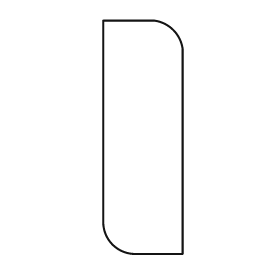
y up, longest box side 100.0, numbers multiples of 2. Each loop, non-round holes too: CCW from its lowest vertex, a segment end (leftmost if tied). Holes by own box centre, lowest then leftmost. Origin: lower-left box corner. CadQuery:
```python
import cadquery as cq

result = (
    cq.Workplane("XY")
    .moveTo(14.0, 0.0)
    .lineTo(34.0, 0.0)
    .lineTo(34.0, 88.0)
    .threePointArc((30.0, 96.0), (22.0, 100.0))
    .lineTo(0.0, 100.0)
    .lineTo(0.0, 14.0)
    .threePointArc((4.0, 4.0), (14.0, 0.0))
    .close()
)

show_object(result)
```